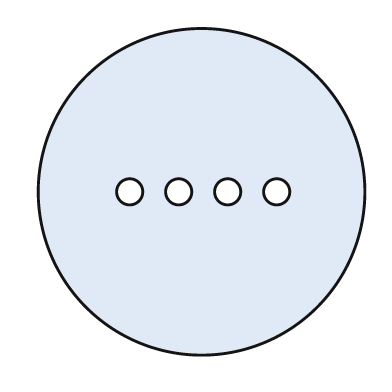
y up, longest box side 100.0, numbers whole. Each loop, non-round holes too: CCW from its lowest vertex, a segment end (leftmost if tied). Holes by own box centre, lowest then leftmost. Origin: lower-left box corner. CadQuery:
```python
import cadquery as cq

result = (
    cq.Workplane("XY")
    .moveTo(50.0, 50.0)
    .circle(50.0)
    .moveTo(28.0, 50.0)
    .circle(4.0)
    .moveTo(43.0, 50.0)
    .circle(4.0)
    .moveTo(58.0, 50.0)
    .circle(4.0)
    .moveTo(73.0, 50.0)
    .circle(4.0)
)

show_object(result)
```